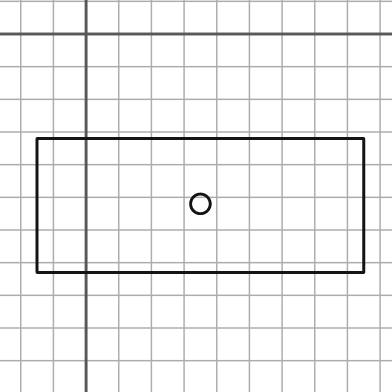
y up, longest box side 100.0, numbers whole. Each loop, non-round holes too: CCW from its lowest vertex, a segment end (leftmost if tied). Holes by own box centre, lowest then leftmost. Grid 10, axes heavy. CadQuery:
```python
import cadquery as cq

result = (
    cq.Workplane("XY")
    .moveTo(-15.0, -73.0)
    .lineTo(85.0, -73.0)
    .lineTo(85.0, -32.0)
    .lineTo(-15.0, -32.0)
    .close()
    .moveTo(35.0, -52.0)
    .circle(3.0)
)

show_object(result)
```